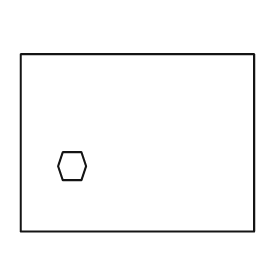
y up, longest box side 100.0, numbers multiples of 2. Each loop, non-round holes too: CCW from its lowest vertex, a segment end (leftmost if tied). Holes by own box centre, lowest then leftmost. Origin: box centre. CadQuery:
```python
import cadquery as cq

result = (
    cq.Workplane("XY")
    .moveTo(-50.0, -38.0)
    .lineTo(50.0, -38.0)
    .lineTo(50.0, 38.0)
    .lineTo(-50.0, 38.0)
    .close()
    .moveTo(-32.0, -16.0)
    .lineTo(-24.0, -16.0)
    .lineTo(-22.0, -10.0)
    .lineTo(-24.0, -4.0)
    .lineTo(-32.0, -4.0)
    .lineTo(-34.0, -10.0)
    .close()
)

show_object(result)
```